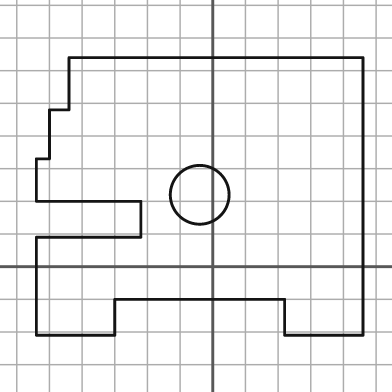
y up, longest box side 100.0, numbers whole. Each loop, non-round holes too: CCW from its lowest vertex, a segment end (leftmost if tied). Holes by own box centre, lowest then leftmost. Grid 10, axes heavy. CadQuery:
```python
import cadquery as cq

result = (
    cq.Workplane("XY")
    .moveTo(-54.0, -21.0)
    .lineTo(-30.0, -21.0)
    .lineTo(-30.0, -10.0)
    .lineTo(22.0, -10.0)
    .lineTo(22.0, -21.0)
    .lineTo(46.0, -21.0)
    .lineTo(46.0, 64.0)
    .lineTo(-44.0, 64.0)
    .lineTo(-44.0, 48.0)
    .lineTo(-50.0, 48.0)
    .lineTo(-50.0, 33.0)
    .lineTo(-54.0, 33.0)
    .lineTo(-54.0, 20.0)
    .lineTo(-22.0, 20.0)
    .lineTo(-22.0, 9.0)
    .lineTo(-54.0, 9.0)
    .close()
    .moveTo(-4.0, 22.0)
    .circle(9.0)
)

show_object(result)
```